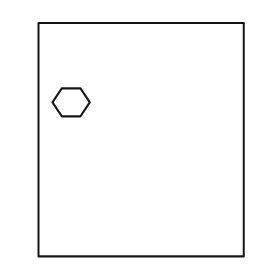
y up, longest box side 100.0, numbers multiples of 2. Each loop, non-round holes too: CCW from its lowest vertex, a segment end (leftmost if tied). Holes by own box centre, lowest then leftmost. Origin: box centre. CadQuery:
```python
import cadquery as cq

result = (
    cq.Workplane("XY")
    .moveTo(-44.0, -50.0)
    .lineTo(44.0, -50.0)
    .lineTo(44.0, 50.0)
    .lineTo(-44.0, 50.0)
    .close()
    .moveTo(-34.0, 10.0)
    .lineTo(-26.0, 10.0)
    .lineTo(-22.0, 16.0)
    .lineTo(-26.0, 22.0)
    .lineTo(-34.0, 22.0)
    .lineTo(-38.0, 16.0)
    .close()
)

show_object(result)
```